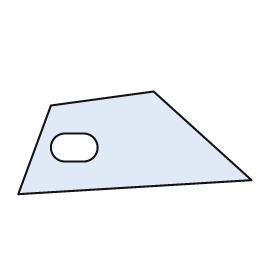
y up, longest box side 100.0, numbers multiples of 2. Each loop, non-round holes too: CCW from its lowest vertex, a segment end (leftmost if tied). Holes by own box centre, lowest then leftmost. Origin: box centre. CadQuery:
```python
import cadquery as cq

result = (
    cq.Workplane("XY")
    .moveTo(-50.0, -22.0)
    .lineTo(50.0, -16.0)
    .lineTo(8.0, 22.0)
    .lineTo(-36.0, 16.0)
    .close()
    .moveTo(-30.0, -8.0)
    .lineTo(-22.0, -8.0)
    .threePointArc((-16.0, -2.0), (-22.0, 4.0))
    .lineTo(-30.0, 4.0)
    .threePointArc((-36.0, -2.0), (-30.0, -8.0))
    .close()
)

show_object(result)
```